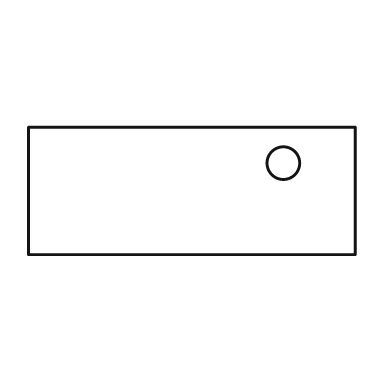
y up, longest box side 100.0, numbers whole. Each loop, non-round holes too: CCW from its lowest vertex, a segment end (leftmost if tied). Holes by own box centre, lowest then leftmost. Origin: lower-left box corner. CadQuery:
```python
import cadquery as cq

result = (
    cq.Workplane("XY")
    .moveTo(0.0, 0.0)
    .lineTo(100.0, 0.0)
    .lineTo(100.0, 39.0)
    .lineTo(0.0, 39.0)
    .close()
    .moveTo(78.0, 28.0)
    .circle(5.0)
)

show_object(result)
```